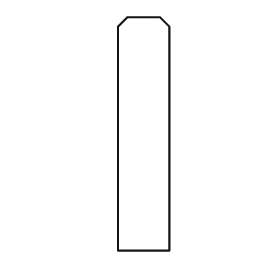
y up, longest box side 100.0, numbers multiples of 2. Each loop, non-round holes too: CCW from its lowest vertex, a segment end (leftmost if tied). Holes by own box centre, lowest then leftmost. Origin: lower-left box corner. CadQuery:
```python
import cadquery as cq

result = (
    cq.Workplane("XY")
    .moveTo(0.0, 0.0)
    .lineTo(22.0, 0.0)
    .lineTo(22.0, 96.0)
    .lineTo(18.0, 100.0)
    .lineTo(4.0, 100.0)
    .lineTo(0.0, 96.0)
    .close()
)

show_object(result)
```